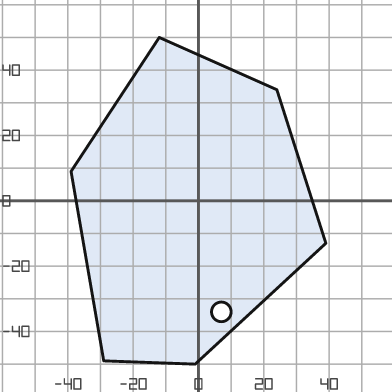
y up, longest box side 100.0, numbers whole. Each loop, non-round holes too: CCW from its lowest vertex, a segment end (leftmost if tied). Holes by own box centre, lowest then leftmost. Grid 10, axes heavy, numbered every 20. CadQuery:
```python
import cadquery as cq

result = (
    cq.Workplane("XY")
    .moveTo(-1.0, -50.0)
    .lineTo(39.0, -13.0)
    .lineTo(24.0, 34.0)
    .lineTo(-12.0, 50.0)
    .lineTo(-39.0, 9.0)
    .lineTo(-29.0, -49.0)
    .close()
    .moveTo(7.0, -34.0)
    .circle(3.0)
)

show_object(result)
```